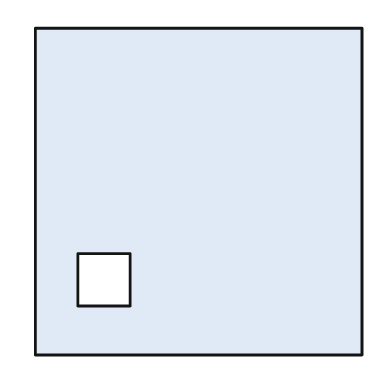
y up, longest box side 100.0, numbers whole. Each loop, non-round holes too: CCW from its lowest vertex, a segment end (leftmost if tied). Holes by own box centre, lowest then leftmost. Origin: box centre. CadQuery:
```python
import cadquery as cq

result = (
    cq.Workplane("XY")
    .moveTo(-50.0, -50.0)
    .lineTo(50.0, -50.0)
    .lineTo(50.0, 50.0)
    .lineTo(-50.0, 50.0)
    .close()
    .moveTo(-37.0, -35.0)
    .lineTo(-21.0, -35.0)
    .lineTo(-21.0, -19.0)
    .lineTo(-37.0, -19.0)
    .close()
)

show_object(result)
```